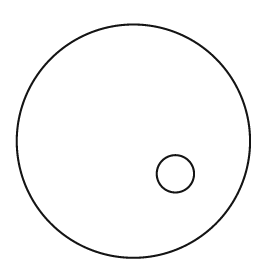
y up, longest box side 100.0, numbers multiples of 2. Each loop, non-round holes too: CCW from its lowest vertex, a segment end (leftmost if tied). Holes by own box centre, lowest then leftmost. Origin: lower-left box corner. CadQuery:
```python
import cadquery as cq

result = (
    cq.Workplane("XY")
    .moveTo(50.0, 50.0)
    .circle(50.0)
    .moveTo(68.0, 36.0)
    .circle(8.0)
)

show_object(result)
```